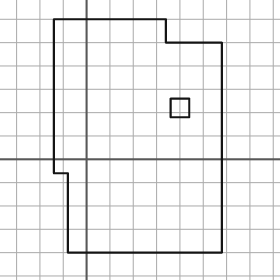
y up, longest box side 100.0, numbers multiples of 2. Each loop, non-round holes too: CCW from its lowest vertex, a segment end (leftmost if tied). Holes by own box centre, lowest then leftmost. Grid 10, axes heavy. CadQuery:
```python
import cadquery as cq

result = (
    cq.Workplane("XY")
    .moveTo(-8.0, -40.0)
    .lineTo(58.0, -40.0)
    .lineTo(58.0, 50.0)
    .lineTo(34.0, 50.0)
    .lineTo(34.0, 60.0)
    .lineTo(-14.0, 60.0)
    .lineTo(-14.0, -6.0)
    .lineTo(-8.0, -6.0)
    .close()
    .moveTo(36.0, 18.0)
    .lineTo(44.0, 18.0)
    .lineTo(44.0, 26.0)
    .lineTo(36.0, 26.0)
    .close()
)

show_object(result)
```